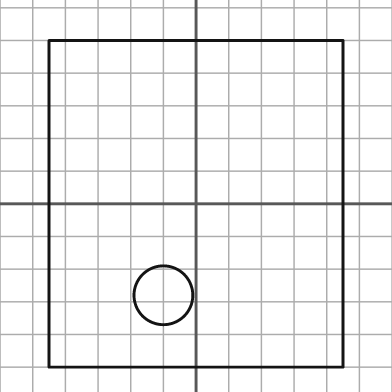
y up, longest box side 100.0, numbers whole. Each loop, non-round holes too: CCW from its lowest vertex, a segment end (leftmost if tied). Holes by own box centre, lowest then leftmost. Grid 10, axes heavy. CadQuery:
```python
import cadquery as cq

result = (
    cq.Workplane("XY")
    .moveTo(-45.0, -50.0)
    .lineTo(45.0, -50.0)
    .lineTo(45.0, 50.0)
    .lineTo(-45.0, 50.0)
    .close()
    .moveTo(-10.0, -28.0)
    .circle(9.0)
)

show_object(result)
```